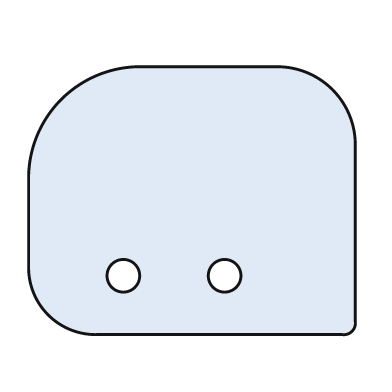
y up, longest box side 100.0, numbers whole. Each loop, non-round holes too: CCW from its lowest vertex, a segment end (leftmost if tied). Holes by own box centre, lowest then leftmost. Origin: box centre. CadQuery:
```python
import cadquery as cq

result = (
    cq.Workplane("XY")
    .moveTo(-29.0, -41.0)
    .lineTo(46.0, -41.0)
    .threePointArc((49.0, -40.0), (50.0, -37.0))
    .lineTo(50.0, 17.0)
    .threePointArc((43.0, 34.0), (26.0, 41.0))
    .lineTo(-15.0, 41.0)
    .threePointArc((-40.0, 31.0), (-50.0, 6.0))
    .lineTo(-50.0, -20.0)
    .threePointArc((-44.0, -35.0), (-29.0, -41.0))
    .close()
    .moveTo(-21.0, -23.0)
    .circle(5.0)
    .moveTo(10.0, -23.0)
    .circle(5.0)
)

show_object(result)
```